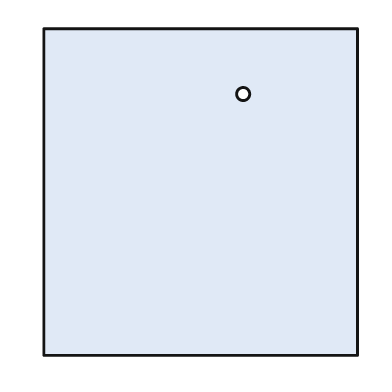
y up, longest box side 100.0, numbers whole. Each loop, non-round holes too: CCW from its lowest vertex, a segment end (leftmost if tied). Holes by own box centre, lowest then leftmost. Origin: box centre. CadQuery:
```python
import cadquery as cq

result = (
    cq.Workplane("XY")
    .moveTo(-48.0, -50.0)
    .lineTo(48.0, -50.0)
    .lineTo(48.0, 50.0)
    .lineTo(-48.0, 50.0)
    .close()
    .moveTo(13.0, 30.0)
    .circle(2.0)
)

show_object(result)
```